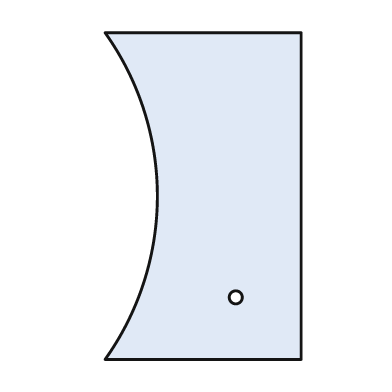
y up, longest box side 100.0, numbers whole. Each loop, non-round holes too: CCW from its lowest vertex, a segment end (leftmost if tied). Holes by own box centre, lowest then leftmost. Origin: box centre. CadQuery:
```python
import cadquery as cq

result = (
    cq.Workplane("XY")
    .moveTo(-30.0, -50.0)
    .lineTo(30.0, -50.0)
    .lineTo(30.0, 50.0)
    .lineTo(-30.0, 50.0)
    .threePointArc((-14.0, 0.0), (-30.0, -50.0))
    .close()
    .moveTo(10.0, -31.0)
    .circle(2.0)
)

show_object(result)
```